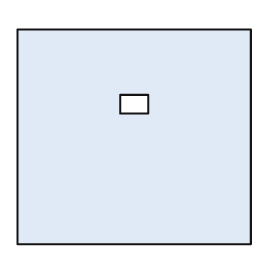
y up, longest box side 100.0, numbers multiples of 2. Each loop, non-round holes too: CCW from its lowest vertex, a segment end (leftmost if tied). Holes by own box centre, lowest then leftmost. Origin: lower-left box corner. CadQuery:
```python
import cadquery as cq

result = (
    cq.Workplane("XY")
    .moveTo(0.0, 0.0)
    .lineTo(100.0, 0.0)
    .lineTo(100.0, 92.0)
    .lineTo(0.0, 92.0)
    .close()
    .moveTo(44.0, 56.0)
    .lineTo(56.0, 56.0)
    .lineTo(56.0, 64.0)
    .lineTo(44.0, 64.0)
    .close()
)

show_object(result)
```